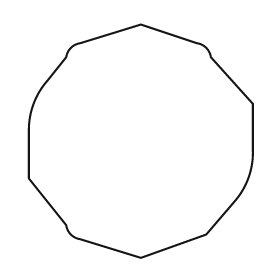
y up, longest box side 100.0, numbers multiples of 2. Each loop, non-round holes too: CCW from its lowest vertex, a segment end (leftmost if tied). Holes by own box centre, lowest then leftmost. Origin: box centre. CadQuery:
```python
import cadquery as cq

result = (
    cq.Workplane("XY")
    .moveTo(0.0, -50.0)
    .lineTo(28.0, -40.0)
    .lineTo(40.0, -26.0)
    .threePointArc((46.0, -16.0), (48.0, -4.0))
    .lineTo(48.0, 16.0)
    .lineTo(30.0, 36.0)
    .threePointArc((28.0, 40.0), (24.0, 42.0))
    .lineTo(0.0, 50.0)
    .lineTo(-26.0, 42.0)
    .threePointArc((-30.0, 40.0), (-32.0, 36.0))
    .lineTo(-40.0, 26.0)
    .threePointArc((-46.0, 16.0), (-48.0, 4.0))
    .lineTo(-48.0, -16.0)
    .lineTo(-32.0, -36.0)
    .threePointArc((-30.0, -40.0), (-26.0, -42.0))
    .close()
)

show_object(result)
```